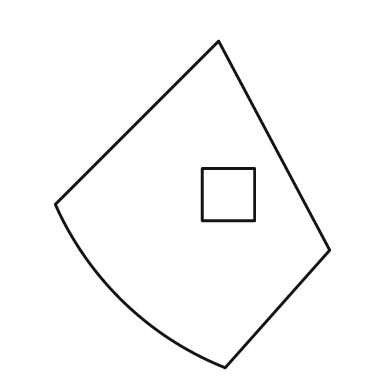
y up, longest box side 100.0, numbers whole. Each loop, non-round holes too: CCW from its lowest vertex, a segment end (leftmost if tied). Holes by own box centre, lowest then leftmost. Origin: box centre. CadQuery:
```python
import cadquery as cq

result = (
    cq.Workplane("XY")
    .moveTo(10.0, -50.0)
    .lineTo(42.0, -14.0)
    .lineTo(8.0, 50.0)
    .lineTo(-42.0, 0.0)
    .threePointArc((-21.0, -30.0), (10.0, -50.0))
    .close()
    .moveTo(3.0, -5.0)
    .lineTo(19.0, -5.0)
    .lineTo(19.0, 11.0)
    .lineTo(3.0, 11.0)
    .close()
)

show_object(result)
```